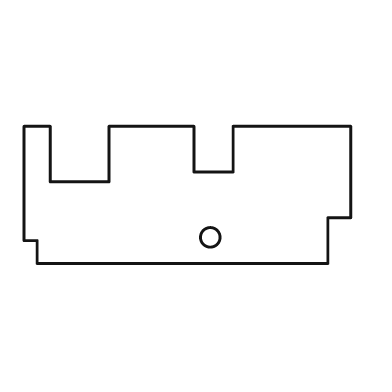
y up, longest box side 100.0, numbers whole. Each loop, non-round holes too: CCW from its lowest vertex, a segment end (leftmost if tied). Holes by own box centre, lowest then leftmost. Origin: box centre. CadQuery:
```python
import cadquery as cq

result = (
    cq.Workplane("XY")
    .moveTo(-46.0, -21.0)
    .lineTo(43.0, -21.0)
    .lineTo(43.0, -7.0)
    .lineTo(50.0, -7.0)
    .lineTo(50.0, 21.0)
    .lineTo(14.0, 21.0)
    .lineTo(14.0, 7.0)
    .lineTo(2.0, 7.0)
    .lineTo(2.0, 21.0)
    .lineTo(-24.0, 21.0)
    .lineTo(-24.0, 4.0)
    .lineTo(-42.0, 4.0)
    .lineTo(-42.0, 21.0)
    .lineTo(-50.0, 21.0)
    .lineTo(-50.0, -14.0)
    .lineTo(-46.0, -14.0)
    .close()
    .moveTo(7.0, -13.0)
    .circle(3.0)
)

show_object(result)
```